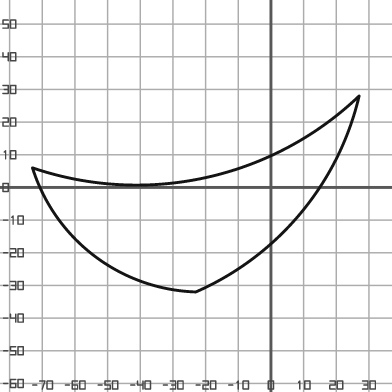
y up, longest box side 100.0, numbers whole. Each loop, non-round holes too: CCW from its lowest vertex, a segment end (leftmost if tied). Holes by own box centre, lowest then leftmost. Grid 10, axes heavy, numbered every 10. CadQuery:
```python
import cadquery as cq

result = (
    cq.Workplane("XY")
    .moveTo(-23.0, -32.0)
    .threePointArc((9.0, -8.0), (27.0, 28.0))
    .threePointArc((-20.0, 3.0), (-73.0, 6.0))
    .threePointArc((-54.0, -21.0), (-23.0, -32.0))
    .close()
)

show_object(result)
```